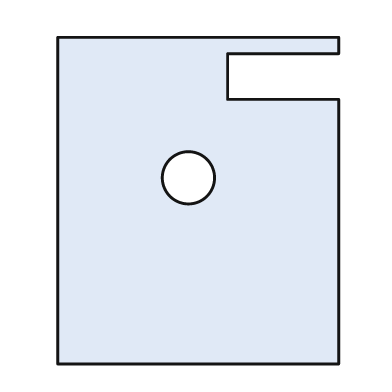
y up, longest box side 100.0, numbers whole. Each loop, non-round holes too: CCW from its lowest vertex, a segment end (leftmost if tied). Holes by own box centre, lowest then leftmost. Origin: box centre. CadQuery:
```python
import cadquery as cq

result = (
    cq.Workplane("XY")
    .moveTo(-43.0, -50.0)
    .lineTo(43.0, -50.0)
    .lineTo(43.0, 31.0)
    .lineTo(9.0, 31.0)
    .lineTo(9.0, 45.0)
    .lineTo(43.0, 45.0)
    .lineTo(43.0, 50.0)
    .lineTo(-43.0, 50.0)
    .close()
    .moveTo(-3.0, 7.0)
    .circle(8.0)
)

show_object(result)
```